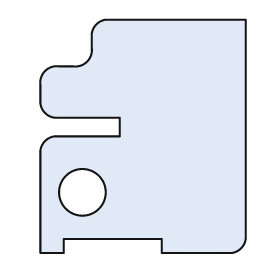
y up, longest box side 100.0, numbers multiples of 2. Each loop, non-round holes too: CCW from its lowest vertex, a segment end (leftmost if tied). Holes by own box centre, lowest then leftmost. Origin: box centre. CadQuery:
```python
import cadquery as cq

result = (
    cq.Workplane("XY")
    .moveTo(-44.0, -50.0)
    .lineTo(-34.0, -50.0)
    .lineTo(-34.0, -44.0)
    .lineTo(8.0, -44.0)
    .lineTo(8.0, -50.0)
    .lineTo(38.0, -50.0)
    .threePointArc((42.0, -48.0), (44.0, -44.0))
    .lineTo(44.0, 50.0)
    .lineTo(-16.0, 50.0)
    .threePointArc((-20.0, 48.0), (-22.0, 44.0))
    .lineTo(-22.0, 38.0)
    .threePointArc((-24.0, 32.0), (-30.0, 30.0))
    .lineTo(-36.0, 30.0)
    .threePointArc((-42.0, 28.0), (-44.0, 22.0))
    .lineTo(-44.0, 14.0)
    .threePointArc((-42.0, 10.0), (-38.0, 8.0))
    .lineTo(-10.0, 8.0)
    .lineTo(-10.0, 0.0)
    .lineTo(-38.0, 0.0)
    .threePointArc((-42.0, -2.0), (-44.0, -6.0))
    .close()
    .moveTo(-26.0, -24.0)
    .circle(10.0)
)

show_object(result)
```